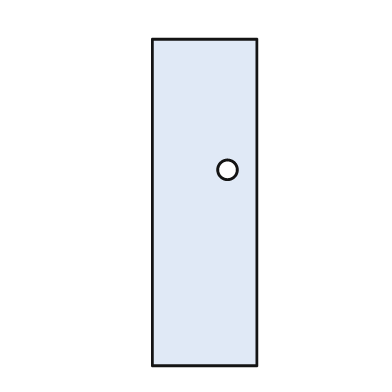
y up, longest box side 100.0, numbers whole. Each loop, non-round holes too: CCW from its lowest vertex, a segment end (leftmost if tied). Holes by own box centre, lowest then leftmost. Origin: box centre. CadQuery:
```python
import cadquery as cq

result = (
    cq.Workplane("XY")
    .moveTo(-16.0, -50.0)
    .lineTo(16.0, -50.0)
    .lineTo(16.0, 50.0)
    .lineTo(-16.0, 50.0)
    .close()
    .moveTo(7.0, 10.0)
    .circle(3.0)
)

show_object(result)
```